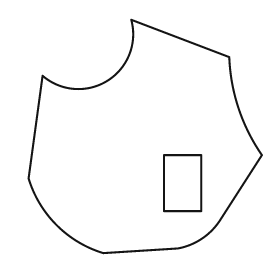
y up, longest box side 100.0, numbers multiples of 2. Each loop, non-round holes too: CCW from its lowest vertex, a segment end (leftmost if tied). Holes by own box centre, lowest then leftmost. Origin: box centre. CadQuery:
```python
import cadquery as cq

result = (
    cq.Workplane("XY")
    .moveTo(-18.0, -50.0)
    .lineTo(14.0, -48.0)
    .threePointArc((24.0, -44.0), (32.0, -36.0))
    .lineTo(50.0, -8.0)
    .threePointArc((40.0, 12.0), (36.0, 34.0))
    .lineTo(-6.0, 50.0)
    .threePointArc((-16.0, 24.0), (-44.0, 26.0))
    .lineTo(-50.0, -18.0)
    .threePointArc((-38.0, -38.0), (-18.0, -50.0))
    .close()
    .moveTo(8.0, -32.0)
    .lineTo(24.0, -32.0)
    .lineTo(24.0, -8.0)
    .lineTo(8.0, -8.0)
    .close()
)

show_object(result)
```